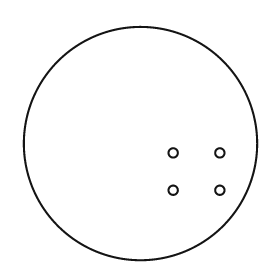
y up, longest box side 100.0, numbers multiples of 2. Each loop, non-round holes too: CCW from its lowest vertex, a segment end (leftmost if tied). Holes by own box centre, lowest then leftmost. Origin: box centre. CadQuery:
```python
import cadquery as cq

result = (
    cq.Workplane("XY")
    .moveTo(0.0, 0.0)
    .circle(50.0)
    .moveTo(14.0, -20.0)
    .circle(2.0)
    .moveTo(34.0, -20.0)
    .circle(2.0)
    .moveTo(14.0, -4.0)
    .circle(2.0)
    .moveTo(34.0, -4.0)
    .circle(2.0)
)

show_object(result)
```